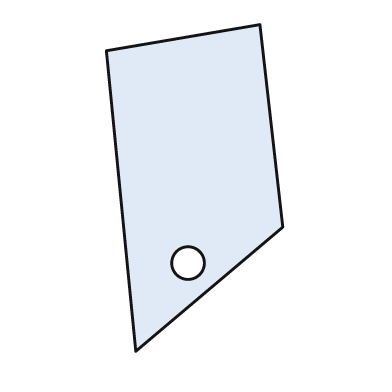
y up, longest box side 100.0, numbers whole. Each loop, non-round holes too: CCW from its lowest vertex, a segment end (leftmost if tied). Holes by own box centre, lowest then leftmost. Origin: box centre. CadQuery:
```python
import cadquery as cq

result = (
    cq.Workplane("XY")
    .moveTo(-18.0, -50.0)
    .lineTo(27.0, -12.0)
    .lineTo(20.0, 50.0)
    .lineTo(-27.0, 42.0)
    .close()
    .moveTo(-2.0, -23.0)
    .circle(5.0)
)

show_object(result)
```